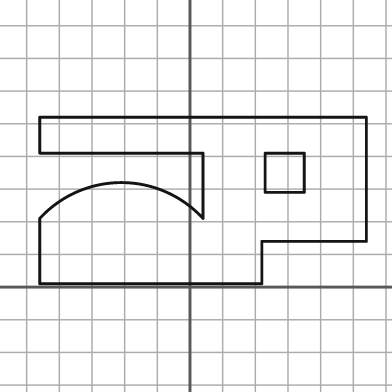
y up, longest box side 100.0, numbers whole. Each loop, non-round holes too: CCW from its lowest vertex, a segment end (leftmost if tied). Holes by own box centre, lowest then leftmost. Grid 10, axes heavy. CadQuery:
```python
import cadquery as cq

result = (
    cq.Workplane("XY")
    .moveTo(-46.0, 1.0)
    .lineTo(22.0, 1.0)
    .lineTo(22.0, 14.0)
    .lineTo(54.0, 14.0)
    .lineTo(54.0, 52.0)
    .lineTo(-46.0, 52.0)
    .lineTo(-46.0, 41.0)
    .lineTo(4.0, 41.0)
    .lineTo(4.0, 21.0)
    .threePointArc((-21.0, 32.0), (-46.0, 21.0))
    .close()
    .moveTo(23.0, 29.0)
    .lineTo(35.0, 29.0)
    .lineTo(35.0, 41.0)
    .lineTo(23.0, 41.0)
    .close()
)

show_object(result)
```